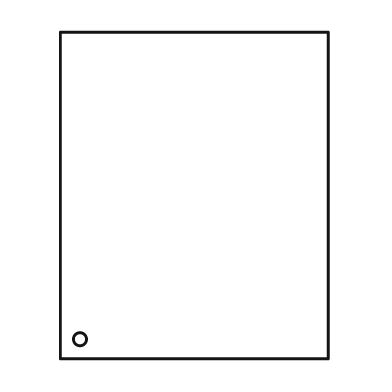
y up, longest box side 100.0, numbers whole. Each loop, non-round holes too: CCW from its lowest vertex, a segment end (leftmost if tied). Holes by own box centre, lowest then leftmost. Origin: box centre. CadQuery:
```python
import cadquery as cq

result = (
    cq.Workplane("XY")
    .moveTo(-41.0, -50.0)
    .lineTo(41.0, -50.0)
    .lineTo(41.0, 50.0)
    .lineTo(-41.0, 50.0)
    .close()
    .moveTo(-35.0, -44.0)
    .circle(2.0)
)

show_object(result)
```